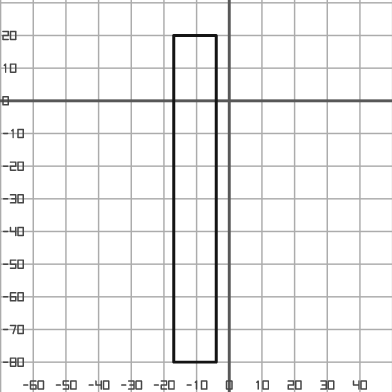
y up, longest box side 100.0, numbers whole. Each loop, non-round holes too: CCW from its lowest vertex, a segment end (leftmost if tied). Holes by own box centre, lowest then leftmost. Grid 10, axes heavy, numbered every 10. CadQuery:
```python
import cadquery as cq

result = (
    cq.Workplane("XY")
    .moveTo(-17.0, -80.0)
    .lineTo(-4.0, -80.0)
    .lineTo(-4.0, 20.0)
    .lineTo(-17.0, 20.0)
    .close()
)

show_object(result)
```